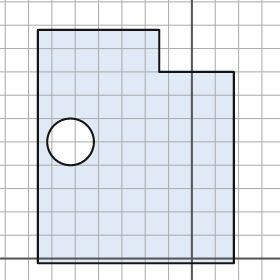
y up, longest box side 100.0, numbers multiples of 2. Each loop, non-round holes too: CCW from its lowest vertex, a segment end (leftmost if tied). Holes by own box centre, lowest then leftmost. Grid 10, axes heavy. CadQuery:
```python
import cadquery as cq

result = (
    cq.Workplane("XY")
    .moveTo(-66.0, -2.0)
    .lineTo(18.0, -2.0)
    .lineTo(18.0, 80.0)
    .lineTo(-14.0, 80.0)
    .lineTo(-14.0, 98.0)
    .lineTo(-66.0, 98.0)
    .close()
    .moveTo(-52.0, 50.0)
    .circle(10.0)
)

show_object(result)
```